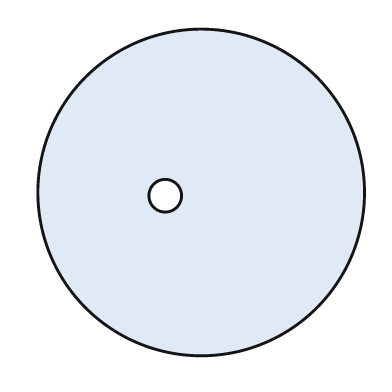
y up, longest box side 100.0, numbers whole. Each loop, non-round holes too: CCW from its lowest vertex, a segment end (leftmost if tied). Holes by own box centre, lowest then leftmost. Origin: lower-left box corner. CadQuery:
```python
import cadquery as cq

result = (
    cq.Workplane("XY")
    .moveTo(50.0, 50.0)
    .circle(50.0)
    .moveTo(39.0, 49.0)
    .circle(5.0)
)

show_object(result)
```